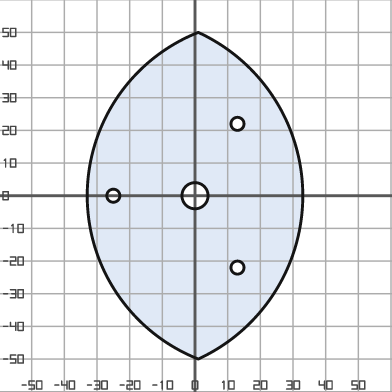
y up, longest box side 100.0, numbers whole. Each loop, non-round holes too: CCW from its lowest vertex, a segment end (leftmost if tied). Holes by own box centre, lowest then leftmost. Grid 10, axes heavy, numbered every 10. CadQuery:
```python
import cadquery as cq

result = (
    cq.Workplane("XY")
    .moveTo(1.0, -50.0)
    .threePointArc((33.0, 0.0), (1.0, 50.0))
    .threePointArc((-33.0, 0.0), (1.0, -50.0))
    .close()
    .moveTo(13.0, -22.0)
    .circle(2.0)
    .moveTo(-25.0, 0.0)
    .circle(2.0)
    .moveTo(0.0, 0.0)
    .circle(4.0)
    .moveTo(13.0, 22.0)
    .circle(2.0)
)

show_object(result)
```